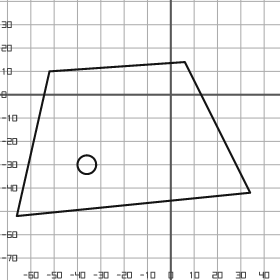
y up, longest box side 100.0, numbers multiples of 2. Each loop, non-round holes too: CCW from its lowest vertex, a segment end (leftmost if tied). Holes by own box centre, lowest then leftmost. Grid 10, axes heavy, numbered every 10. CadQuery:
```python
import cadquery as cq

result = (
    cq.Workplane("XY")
    .moveTo(-66.0, -52.0)
    .lineTo(34.0, -42.0)
    .lineTo(6.0, 14.0)
    .lineTo(-52.0, 10.0)
    .close()
    .moveTo(-36.0, -30.0)
    .circle(4.0)
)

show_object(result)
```